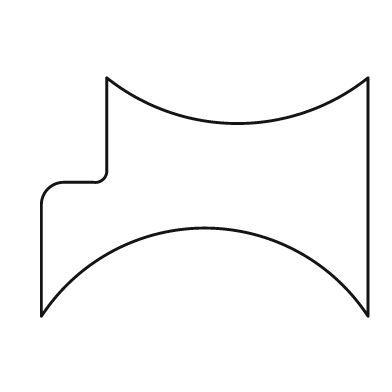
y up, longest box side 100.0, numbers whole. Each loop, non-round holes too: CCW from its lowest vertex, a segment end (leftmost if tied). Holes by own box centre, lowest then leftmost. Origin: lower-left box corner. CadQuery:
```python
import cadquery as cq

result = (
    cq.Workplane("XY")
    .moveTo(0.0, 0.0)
    .threePointArc((50.0, 27.0), (100.0, 0.0))
    .lineTo(100.0, 73.0)
    .threePointArc((60.0, 59.0), (20.0, 73.0))
    .lineTo(20.0, 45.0)
    .threePointArc((19.0, 42.0), (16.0, 41.0))
    .lineTo(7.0, 41.0)
    .threePointArc((2.0, 39.0), (0.0, 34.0))
    .close()
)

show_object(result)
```